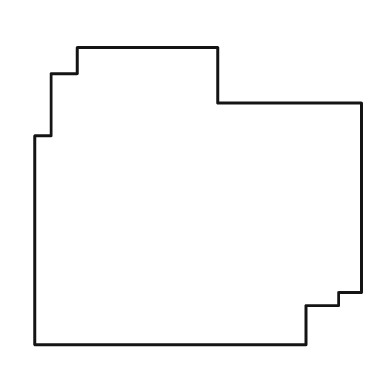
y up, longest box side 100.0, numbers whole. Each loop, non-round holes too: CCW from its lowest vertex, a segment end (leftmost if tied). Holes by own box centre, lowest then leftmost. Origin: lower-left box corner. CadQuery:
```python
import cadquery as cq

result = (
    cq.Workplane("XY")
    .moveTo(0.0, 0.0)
    .lineTo(83.0, 0.0)
    .lineTo(83.0, 12.0)
    .lineTo(93.0, 12.0)
    .lineTo(93.0, 16.0)
    .lineTo(100.0, 16.0)
    .lineTo(100.0, 74.0)
    .lineTo(56.0, 74.0)
    .lineTo(56.0, 91.0)
    .lineTo(13.0, 91.0)
    .lineTo(13.0, 83.0)
    .lineTo(5.0, 83.0)
    .lineTo(5.0, 64.0)
    .lineTo(0.0, 64.0)
    .close()
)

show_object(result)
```